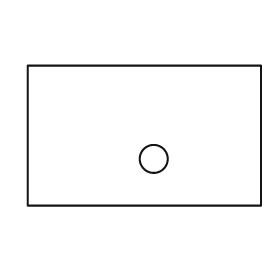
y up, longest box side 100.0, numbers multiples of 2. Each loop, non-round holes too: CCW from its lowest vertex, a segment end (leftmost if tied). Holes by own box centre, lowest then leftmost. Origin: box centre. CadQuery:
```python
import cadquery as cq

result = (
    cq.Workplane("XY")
    .moveTo(-50.0, -30.0)
    .lineTo(50.0, -30.0)
    .lineTo(50.0, 30.0)
    .lineTo(-50.0, 30.0)
    .close()
    .moveTo(4.0, -10.0)
    .circle(6.0)
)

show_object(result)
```